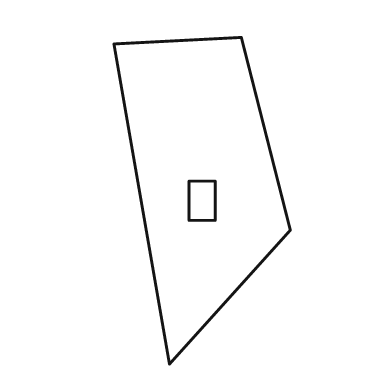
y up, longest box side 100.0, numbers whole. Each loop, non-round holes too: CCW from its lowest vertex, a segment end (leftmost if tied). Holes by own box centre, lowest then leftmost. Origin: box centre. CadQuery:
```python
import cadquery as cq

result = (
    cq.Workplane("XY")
    .moveTo(-10.0, -50.0)
    .lineTo(27.0, -9.0)
    .lineTo(12.0, 50.0)
    .lineTo(-27.0, 48.0)
    .close()
    .moveTo(-4.0, -6.0)
    .lineTo(4.0, -6.0)
    .lineTo(4.0, 6.0)
    .lineTo(-4.0, 6.0)
    .close()
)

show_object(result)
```